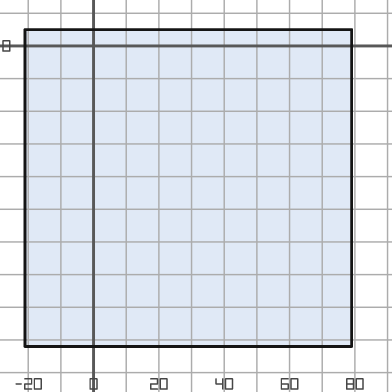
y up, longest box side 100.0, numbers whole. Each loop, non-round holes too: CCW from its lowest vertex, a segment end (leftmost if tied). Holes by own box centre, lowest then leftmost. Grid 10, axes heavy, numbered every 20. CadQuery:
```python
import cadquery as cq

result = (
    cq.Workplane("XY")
    .moveTo(-21.0, -92.0)
    .lineTo(79.0, -92.0)
    .lineTo(79.0, 5.0)
    .lineTo(-21.0, 5.0)
    .close()
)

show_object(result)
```